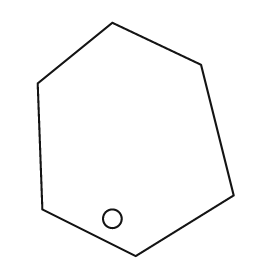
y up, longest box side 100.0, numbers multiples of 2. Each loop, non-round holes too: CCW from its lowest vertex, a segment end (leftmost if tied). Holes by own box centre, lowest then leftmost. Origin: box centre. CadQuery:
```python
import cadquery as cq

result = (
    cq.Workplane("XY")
    .moveTo(0.0, -50.0)
    .lineTo(42.0, -24.0)
    .lineTo(28.0, 32.0)
    .lineTo(-10.0, 50.0)
    .lineTo(-42.0, 24.0)
    .lineTo(-40.0, -30.0)
    .close()
    .moveTo(-10.0, -34.0)
    .circle(4.0)
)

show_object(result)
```